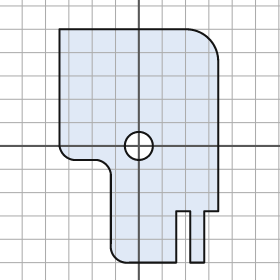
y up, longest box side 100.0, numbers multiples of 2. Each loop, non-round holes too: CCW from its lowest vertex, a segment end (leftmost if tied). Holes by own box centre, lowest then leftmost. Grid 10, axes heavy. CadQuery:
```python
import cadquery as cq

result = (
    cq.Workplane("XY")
    .moveTo(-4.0, -50.0)
    .lineTo(16.0, -50.0)
    .lineTo(16.0, -28.0)
    .lineTo(22.0, -28.0)
    .lineTo(22.0, -50.0)
    .lineTo(28.0, -50.0)
    .lineTo(28.0, -28.0)
    .lineTo(34.0, -28.0)
    .lineTo(34.0, 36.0)
    .threePointArc((30.0, 46.0), (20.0, 50.0))
    .lineTo(-34.0, 50.0)
    .lineTo(-34.0, 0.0)
    .threePointArc((-32.0, -4.0), (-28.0, -6.0))
    .lineTo(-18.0, -6.0)
    .threePointArc((-14.0, -8.0), (-12.0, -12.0))
    .lineTo(-12.0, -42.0)
    .threePointArc((-10.0, -48.0), (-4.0, -50.0))
    .close()
    .moveTo(0.0, 0.0)
    .circle(6.0)
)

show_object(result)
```